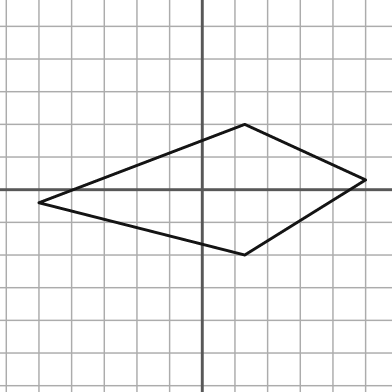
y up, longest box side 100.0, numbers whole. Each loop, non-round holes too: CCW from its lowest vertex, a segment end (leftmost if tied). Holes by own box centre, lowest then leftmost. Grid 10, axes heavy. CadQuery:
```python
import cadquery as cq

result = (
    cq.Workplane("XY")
    .moveTo(13.0, -20.0)
    .lineTo(50.0, 3.0)
    .lineTo(13.0, 20.0)
    .lineTo(-50.0, -4.0)
    .close()
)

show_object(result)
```